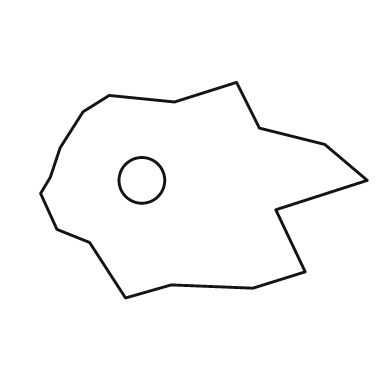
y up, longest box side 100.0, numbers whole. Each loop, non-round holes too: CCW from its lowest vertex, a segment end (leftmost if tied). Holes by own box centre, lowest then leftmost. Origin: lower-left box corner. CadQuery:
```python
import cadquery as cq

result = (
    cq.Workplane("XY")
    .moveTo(26.0, 0.0)
    .lineTo(40.0, 4.0)
    .lineTo(65.0, 3.0)
    .lineTo(81.0, 8.0)
    .lineTo(72.0, 27.0)
    .lineTo(100.0, 36.0)
    .lineTo(87.0, 47.0)
    .lineTo(67.0, 52.0)
    .lineTo(60.0, 66.0)
    .lineTo(41.0, 60.0)
    .lineTo(21.0, 62.0)
    .lineTo(13.0, 57.0)
    .lineTo(6.0, 46.0)
    .lineTo(3.0, 37.0)
    .lineTo(0.0, 32.0)
    .lineTo(5.0, 21.0)
    .lineTo(15.0, 17.0)
    .close()
    .moveTo(31.0, 36.0)
    .circle(7.0)
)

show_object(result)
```